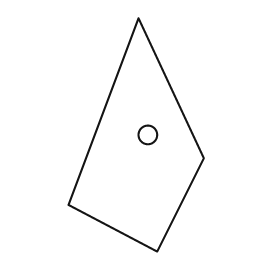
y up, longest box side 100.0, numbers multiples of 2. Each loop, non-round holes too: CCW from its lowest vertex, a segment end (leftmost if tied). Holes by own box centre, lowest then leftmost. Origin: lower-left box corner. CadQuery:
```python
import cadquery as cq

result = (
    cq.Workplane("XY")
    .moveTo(38.0, 0.0)
    .lineTo(58.0, 40.0)
    .lineTo(30.0, 100.0)
    .lineTo(0.0, 20.0)
    .close()
    .moveTo(34.0, 50.0)
    .circle(4.0)
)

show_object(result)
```